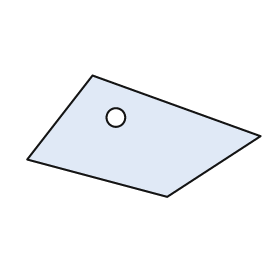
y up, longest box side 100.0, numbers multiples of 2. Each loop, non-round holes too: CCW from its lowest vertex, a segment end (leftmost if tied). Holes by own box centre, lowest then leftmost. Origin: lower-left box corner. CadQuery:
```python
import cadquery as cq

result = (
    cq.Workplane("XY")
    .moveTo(60.0, 0.0)
    .lineTo(100.0, 26.0)
    .lineTo(28.0, 52.0)
    .lineTo(0.0, 16.0)
    .close()
    .moveTo(38.0, 34.0)
    .circle(4.0)
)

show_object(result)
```